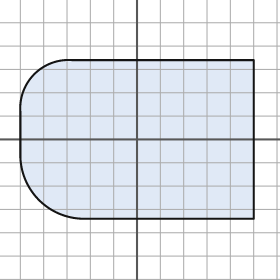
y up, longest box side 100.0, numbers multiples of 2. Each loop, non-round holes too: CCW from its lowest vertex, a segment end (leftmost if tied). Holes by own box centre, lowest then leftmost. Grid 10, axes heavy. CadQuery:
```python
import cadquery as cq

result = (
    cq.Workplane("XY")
    .moveTo(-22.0, -34.0)
    .lineTo(50.0, -34.0)
    .lineTo(50.0, 34.0)
    .lineTo(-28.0, 34.0)
    .threePointArc((-44.0, 28.0), (-50.0, 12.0))
    .lineTo(-50.0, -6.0)
    .threePointArc((-42.0, -26.0), (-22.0, -34.0))
    .close()
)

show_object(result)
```